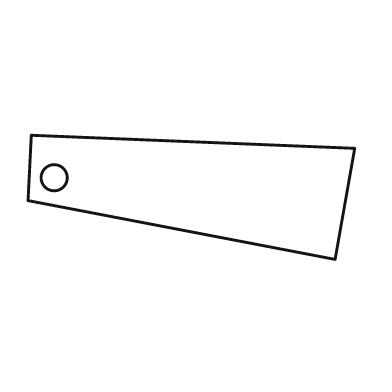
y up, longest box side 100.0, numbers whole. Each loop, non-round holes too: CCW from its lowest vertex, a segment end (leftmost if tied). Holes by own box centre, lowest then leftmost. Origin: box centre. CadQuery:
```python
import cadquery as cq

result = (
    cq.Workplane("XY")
    .moveTo(44.0, -19.0)
    .lineTo(50.0, 15.0)
    .lineTo(-49.0, 19.0)
    .lineTo(-50.0, -1.0)
    .close()
    .moveTo(-42.0, 6.0)
    .circle(4.0)
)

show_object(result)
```